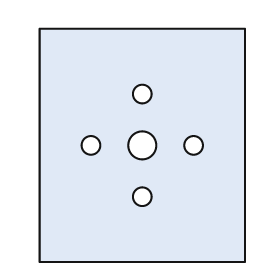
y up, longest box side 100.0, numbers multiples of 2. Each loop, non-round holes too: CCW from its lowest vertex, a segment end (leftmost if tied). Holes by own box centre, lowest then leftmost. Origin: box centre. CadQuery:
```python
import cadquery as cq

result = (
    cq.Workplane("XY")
    .moveTo(-44.0, -50.0)
    .lineTo(44.0, -50.0)
    .lineTo(44.0, 50.0)
    .lineTo(-44.0, 50.0)
    .close()
    .moveTo(0.0, -22.0)
    .circle(4.0)
    .moveTo(-22.0, 0.0)
    .circle(4.0)
    .moveTo(0.0, 0.0)
    .circle(6.0)
    .moveTo(22.0, 0.0)
    .circle(4.0)
    .moveTo(0.0, 22.0)
    .circle(4.0)
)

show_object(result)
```